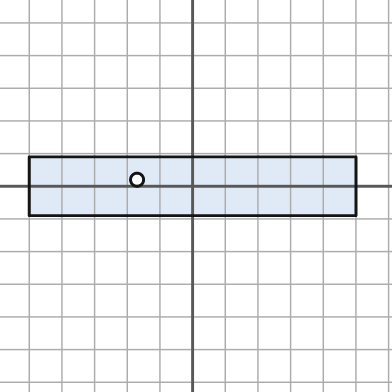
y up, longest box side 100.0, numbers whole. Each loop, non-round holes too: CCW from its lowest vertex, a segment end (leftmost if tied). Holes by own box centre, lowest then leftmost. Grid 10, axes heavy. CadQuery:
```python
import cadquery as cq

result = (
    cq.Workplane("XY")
    .moveTo(-50.0, -9.0)
    .lineTo(50.0, -9.0)
    .lineTo(50.0, 9.0)
    .lineTo(-50.0, 9.0)
    .close()
    .moveTo(-17.0, 2.0)
    .circle(2.0)
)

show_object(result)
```